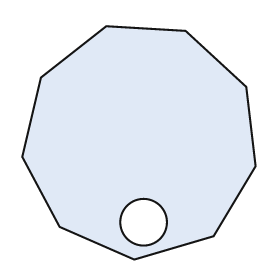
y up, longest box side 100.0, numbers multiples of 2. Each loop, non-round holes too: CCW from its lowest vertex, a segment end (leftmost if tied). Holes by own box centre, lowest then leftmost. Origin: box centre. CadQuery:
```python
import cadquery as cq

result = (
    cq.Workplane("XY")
    .moveTo(-2.0, -50.0)
    .lineTo(32.0, -40.0)
    .lineTo(50.0, -10.0)
    .lineTo(46.0, 24.0)
    .lineTo(20.0, 48.0)
    .lineTo(-14.0, 50.0)
    .lineTo(-42.0, 28.0)
    .lineTo(-50.0, -6.0)
    .lineTo(-34.0, -36.0)
    .close()
    .moveTo(2.0, -34.0)
    .circle(10.0)
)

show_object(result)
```